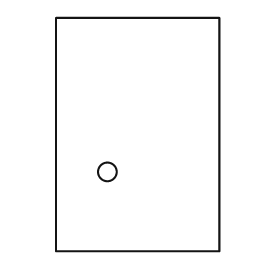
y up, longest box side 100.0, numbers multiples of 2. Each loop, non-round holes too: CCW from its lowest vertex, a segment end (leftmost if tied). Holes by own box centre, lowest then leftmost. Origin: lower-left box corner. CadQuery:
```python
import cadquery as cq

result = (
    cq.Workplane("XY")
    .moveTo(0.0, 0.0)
    .lineTo(70.0, 0.0)
    .lineTo(70.0, 100.0)
    .lineTo(0.0, 100.0)
    .close()
    .moveTo(22.0, 34.0)
    .circle(4.0)
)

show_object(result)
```